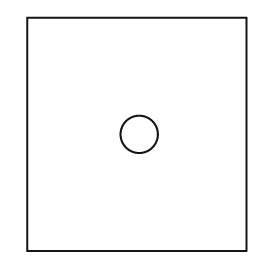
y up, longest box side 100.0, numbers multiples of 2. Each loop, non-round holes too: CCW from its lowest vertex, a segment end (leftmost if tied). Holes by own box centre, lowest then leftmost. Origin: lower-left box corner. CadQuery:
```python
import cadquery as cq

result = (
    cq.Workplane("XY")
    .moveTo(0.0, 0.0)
    .lineTo(94.0, 0.0)
    .lineTo(94.0, 100.0)
    .lineTo(0.0, 100.0)
    .close()
    .moveTo(48.0, 50.0)
    .circle(8.0)
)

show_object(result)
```